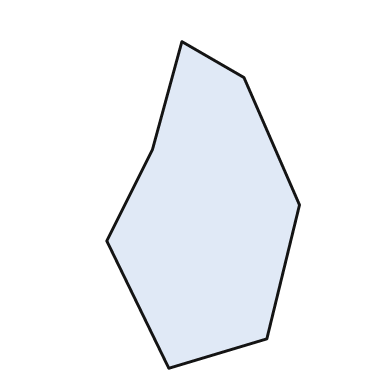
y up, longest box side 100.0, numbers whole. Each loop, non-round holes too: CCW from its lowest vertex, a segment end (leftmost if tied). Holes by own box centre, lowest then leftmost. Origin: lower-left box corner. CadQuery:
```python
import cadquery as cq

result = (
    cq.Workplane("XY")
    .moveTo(19.0, 0.0)
    .lineTo(49.0, 9.0)
    .lineTo(59.0, 50.0)
    .lineTo(42.0, 89.0)
    .lineTo(23.0, 100.0)
    .lineTo(14.0, 67.0)
    .lineTo(0.0, 39.0)
    .close()
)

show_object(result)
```